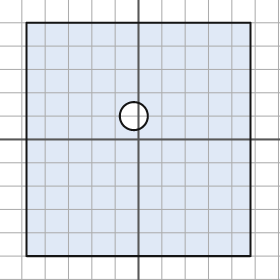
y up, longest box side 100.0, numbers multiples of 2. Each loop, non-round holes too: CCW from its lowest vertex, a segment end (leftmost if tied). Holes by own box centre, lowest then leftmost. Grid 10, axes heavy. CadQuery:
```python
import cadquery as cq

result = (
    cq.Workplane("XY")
    .moveTo(-48.0, -50.0)
    .lineTo(48.0, -50.0)
    .lineTo(48.0, 50.0)
    .lineTo(-48.0, 50.0)
    .close()
    .moveTo(-2.0, 10.0)
    .circle(6.0)
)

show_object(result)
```